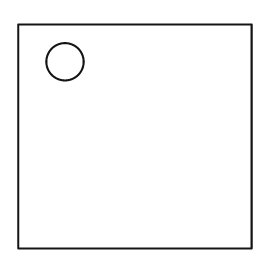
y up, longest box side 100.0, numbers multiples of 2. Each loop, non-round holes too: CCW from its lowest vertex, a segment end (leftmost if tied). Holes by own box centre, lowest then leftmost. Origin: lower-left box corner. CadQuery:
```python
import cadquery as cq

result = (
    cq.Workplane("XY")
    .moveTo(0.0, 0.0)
    .lineTo(100.0, 0.0)
    .lineTo(100.0, 96.0)
    .lineTo(0.0, 96.0)
    .close()
    .moveTo(20.0, 80.0)
    .circle(8.0)
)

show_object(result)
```